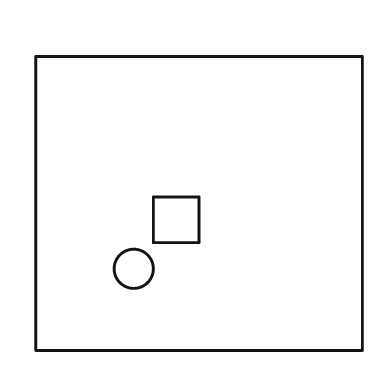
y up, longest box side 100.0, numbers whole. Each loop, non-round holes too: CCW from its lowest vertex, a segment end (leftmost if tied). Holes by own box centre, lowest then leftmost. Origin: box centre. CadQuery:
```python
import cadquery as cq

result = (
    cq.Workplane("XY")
    .moveTo(-50.0, -45.0)
    .lineTo(50.0, -45.0)
    .lineTo(50.0, 45.0)
    .lineTo(-50.0, 45.0)
    .close()
    .moveTo(-20.0, -20.0)
    .circle(6.0)
    .moveTo(-14.0, -12.0)
    .lineTo(0.0, -12.0)
    .lineTo(0.0, 2.0)
    .lineTo(-14.0, 2.0)
    .close()
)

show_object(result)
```